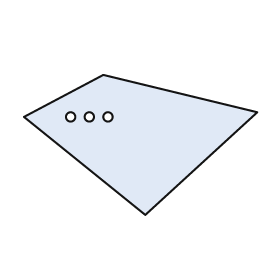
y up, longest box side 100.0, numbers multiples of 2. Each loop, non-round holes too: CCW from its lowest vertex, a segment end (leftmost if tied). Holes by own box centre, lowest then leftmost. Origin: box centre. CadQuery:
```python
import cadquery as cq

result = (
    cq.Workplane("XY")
    .moveTo(2.0, -30.0)
    .lineTo(50.0, 14.0)
    .lineTo(-16.0, 30.0)
    .lineTo(-50.0, 12.0)
    .close()
    .moveTo(-30.0, 12.0)
    .circle(2.0)
    .moveTo(-22.0, 12.0)
    .circle(2.0)
    .moveTo(-14.0, 12.0)
    .circle(2.0)
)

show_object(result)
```